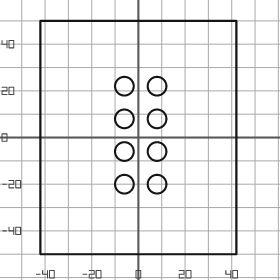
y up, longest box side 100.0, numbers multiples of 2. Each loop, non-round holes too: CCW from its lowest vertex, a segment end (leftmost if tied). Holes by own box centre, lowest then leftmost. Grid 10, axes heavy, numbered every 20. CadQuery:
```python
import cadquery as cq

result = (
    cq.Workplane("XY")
    .moveTo(-42.0, -50.0)
    .lineTo(42.0, -50.0)
    .lineTo(42.0, 50.0)
    .lineTo(-42.0, 50.0)
    .close()
    .moveTo(-6.0, -20.0)
    .circle(4.0)
    .moveTo(8.0, -20.0)
    .circle(4.0)
    .moveTo(-6.0, -6.0)
    .circle(4.0)
    .moveTo(8.0, -6.0)
    .circle(4.0)
    .moveTo(-6.0, 8.0)
    .circle(4.0)
    .moveTo(8.0, 8.0)
    .circle(4.0)
    .moveTo(-6.0, 22.0)
    .circle(4.0)
    .moveTo(8.0, 22.0)
    .circle(4.0)
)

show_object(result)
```